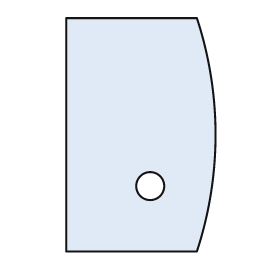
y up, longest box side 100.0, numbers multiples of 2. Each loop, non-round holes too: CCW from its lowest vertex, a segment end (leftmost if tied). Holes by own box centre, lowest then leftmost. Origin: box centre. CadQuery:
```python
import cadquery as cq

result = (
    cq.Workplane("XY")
    .moveTo(-32.0, -50.0)
    .lineTo(24.0, -50.0)
    .threePointArc((32.0, 0.0), (24.0, 50.0))
    .lineTo(-32.0, 50.0)
    .close()
    .moveTo(4.0, -22.0)
    .circle(6.0)
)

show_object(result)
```